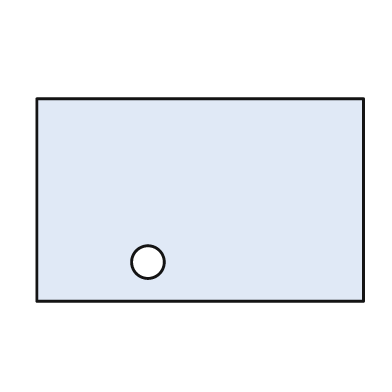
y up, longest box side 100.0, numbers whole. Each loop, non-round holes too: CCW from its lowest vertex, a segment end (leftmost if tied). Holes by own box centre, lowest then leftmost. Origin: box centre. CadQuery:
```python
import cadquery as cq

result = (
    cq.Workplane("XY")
    .moveTo(-50.0, -31.0)
    .lineTo(50.0, -31.0)
    .lineTo(50.0, 31.0)
    .lineTo(-50.0, 31.0)
    .close()
    .moveTo(-16.0, -19.0)
    .circle(5.0)
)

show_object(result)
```